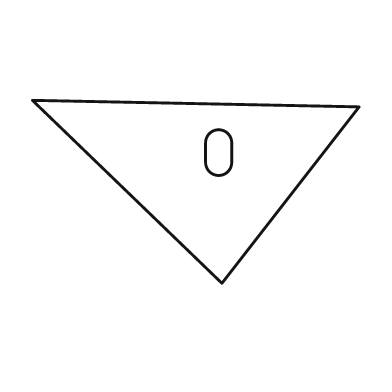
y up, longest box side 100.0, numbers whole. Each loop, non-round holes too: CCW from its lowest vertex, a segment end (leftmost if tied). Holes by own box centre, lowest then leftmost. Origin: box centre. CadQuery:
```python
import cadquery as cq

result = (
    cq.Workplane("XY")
    .moveTo(8.0, -28.0)
    .lineTo(50.0, 26.0)
    .lineTo(-50.0, 28.0)
    .close()
    .moveTo(3.0, 9.0)
    .threePointArc((7.0, 5.0), (11.0, 9.0))
    .lineTo(11.0, 15.0)
    .threePointArc((7.0, 19.0), (3.0, 15.0))
    .close()
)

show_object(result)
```